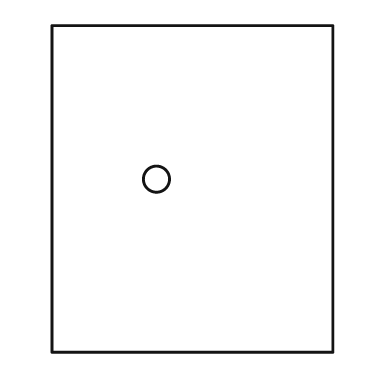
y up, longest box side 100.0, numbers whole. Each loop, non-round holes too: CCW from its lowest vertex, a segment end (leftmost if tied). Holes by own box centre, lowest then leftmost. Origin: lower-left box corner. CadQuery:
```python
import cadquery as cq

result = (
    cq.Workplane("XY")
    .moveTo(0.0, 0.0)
    .lineTo(86.0, 0.0)
    .lineTo(86.0, 100.0)
    .lineTo(0.0, 100.0)
    .close()
    .moveTo(32.0, 53.0)
    .circle(4.0)
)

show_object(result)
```